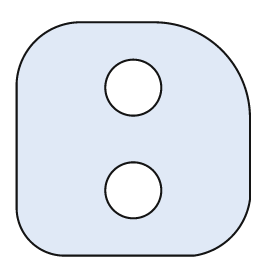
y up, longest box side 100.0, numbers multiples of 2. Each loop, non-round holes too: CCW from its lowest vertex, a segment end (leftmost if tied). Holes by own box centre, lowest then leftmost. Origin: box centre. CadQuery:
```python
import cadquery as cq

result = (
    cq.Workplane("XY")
    .moveTo(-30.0, -50.0)
    .lineTo(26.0, -50.0)
    .threePointArc((42.0, -42.0), (50.0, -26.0))
    .lineTo(50.0, 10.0)
    .threePointArc((38.0, 38.0), (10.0, 50.0))
    .lineTo(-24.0, 50.0)
    .threePointArc((-42.0, 42.0), (-50.0, 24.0))
    .lineTo(-50.0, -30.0)
    .threePointArc((-44.0, -44.0), (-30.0, -50.0))
    .close()
    .moveTo(0.0, -22.0)
    .circle(12.0)
    .moveTo(0.0, 22.0)
    .circle(12.0)
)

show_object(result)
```